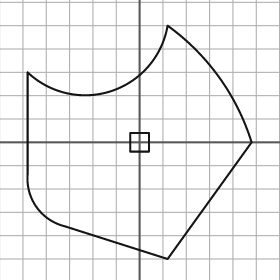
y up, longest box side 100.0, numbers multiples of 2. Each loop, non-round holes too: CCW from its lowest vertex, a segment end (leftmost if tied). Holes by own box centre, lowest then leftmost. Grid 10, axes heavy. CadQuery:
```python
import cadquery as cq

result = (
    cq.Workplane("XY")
    .moveTo(12.0, -50.0)
    .lineTo(48.0, 0.0)
    .threePointArc((34.0, 28.0), (12.0, 50.0))
    .threePointArc((-12.0, 22.0), (-48.0, 30.0))
    .lineTo(-48.0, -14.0)
    .threePointArc((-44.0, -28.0), (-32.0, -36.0))
    .close()
    .moveTo(-4.0, -4.0)
    .lineTo(4.0, -4.0)
    .lineTo(4.0, 4.0)
    .lineTo(-4.0, 4.0)
    .close()
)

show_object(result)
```